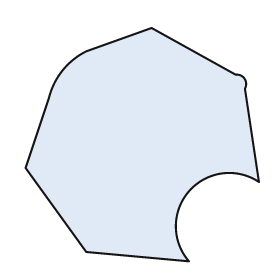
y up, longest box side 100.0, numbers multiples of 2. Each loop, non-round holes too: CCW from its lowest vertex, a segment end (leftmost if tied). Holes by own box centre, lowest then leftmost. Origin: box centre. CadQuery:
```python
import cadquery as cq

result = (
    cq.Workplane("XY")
    .moveTo(20.0, -50.0)
    .threePointArc((20.0, -20.0), (50.0, -16.0))
    .lineTo(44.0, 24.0)
    .threePointArc((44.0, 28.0), (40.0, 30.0))
    .lineTo(4.0, 50.0)
    .lineTo(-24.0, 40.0)
    .threePointArc((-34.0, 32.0), (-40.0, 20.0))
    .lineTo(-50.0, -10.0)
    .lineTo(-24.0, -46.0)
    .close()
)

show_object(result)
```